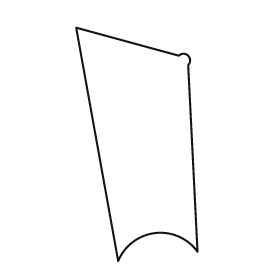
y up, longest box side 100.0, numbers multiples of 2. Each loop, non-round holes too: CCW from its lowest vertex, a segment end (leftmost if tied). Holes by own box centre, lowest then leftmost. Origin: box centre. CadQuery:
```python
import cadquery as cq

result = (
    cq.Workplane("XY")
    .moveTo(-8.0, -50.0)
    .threePointArc((8.0, -38.0), (26.0, -46.0))
    .lineTo(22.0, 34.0)
    .threePointArc((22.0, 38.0), (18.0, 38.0))
    .lineTo(-26.0, 50.0)
    .close()
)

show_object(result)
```